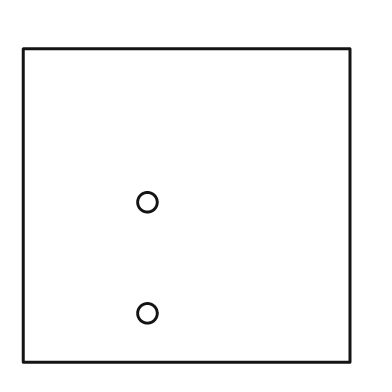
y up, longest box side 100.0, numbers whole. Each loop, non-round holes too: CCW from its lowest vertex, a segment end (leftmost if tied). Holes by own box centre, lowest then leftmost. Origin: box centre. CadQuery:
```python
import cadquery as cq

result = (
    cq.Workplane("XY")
    .moveTo(-50.0, -48.0)
    .lineTo(50.0, -48.0)
    .lineTo(50.0, 48.0)
    .lineTo(-50.0, 48.0)
    .close()
    .moveTo(-12.0, -33.0)
    .circle(3.0)
    .moveTo(-12.0, 1.0)
    .circle(3.0)
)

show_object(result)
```